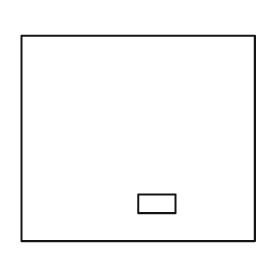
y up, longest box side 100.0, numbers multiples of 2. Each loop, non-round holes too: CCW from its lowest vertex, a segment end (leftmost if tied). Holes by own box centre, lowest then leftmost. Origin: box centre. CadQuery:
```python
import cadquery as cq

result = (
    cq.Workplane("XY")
    .moveTo(-50.0, -44.0)
    .lineTo(50.0, -44.0)
    .lineTo(50.0, 44.0)
    .lineTo(-50.0, 44.0)
    .close()
    .moveTo(0.0, -32.0)
    .lineTo(16.0, -32.0)
    .lineTo(16.0, -24.0)
    .lineTo(0.0, -24.0)
    .close()
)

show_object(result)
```